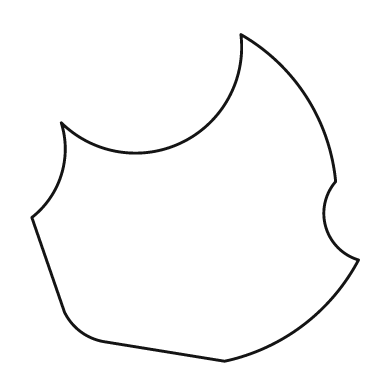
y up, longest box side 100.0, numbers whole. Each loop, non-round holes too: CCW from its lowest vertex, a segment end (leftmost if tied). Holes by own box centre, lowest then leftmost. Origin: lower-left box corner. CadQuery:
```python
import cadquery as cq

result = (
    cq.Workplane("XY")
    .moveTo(59.0, 0.0)
    .threePointArc((83.0, 11.0), (100.0, 31.0))
    .threePointArc((90.0, 41.0), (93.0, 55.0))
    .threePointArc((84.0, 81.0), (64.0, 100.0))
    .threePointArc((46.0, 67.0), (9.0, 73.0))
    .threePointArc((9.0, 57.0), (0.0, 44.0))
    .lineTo(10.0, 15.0)
    .threePointArc((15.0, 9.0), (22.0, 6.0))
    .close()
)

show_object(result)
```